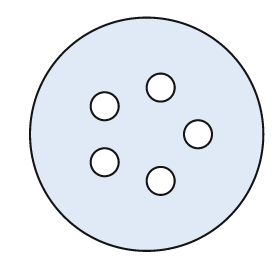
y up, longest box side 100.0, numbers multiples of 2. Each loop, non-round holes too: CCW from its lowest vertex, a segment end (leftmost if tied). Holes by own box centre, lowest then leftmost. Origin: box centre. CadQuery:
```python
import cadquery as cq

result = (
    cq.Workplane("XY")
    .moveTo(0.0, 0.0)
    .circle(50.0)
    .moveTo(6.0, -20.0)
    .circle(6.0)
    .moveTo(-18.0, -12.0)
    .circle(6.0)
    .moveTo(22.0, 0.0)
    .circle(6.0)
    .moveTo(-18.0, 12.0)
    .circle(6.0)
    .moveTo(6.0, 20.0)
    .circle(6.0)
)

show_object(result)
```